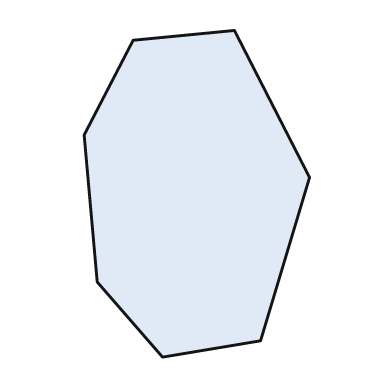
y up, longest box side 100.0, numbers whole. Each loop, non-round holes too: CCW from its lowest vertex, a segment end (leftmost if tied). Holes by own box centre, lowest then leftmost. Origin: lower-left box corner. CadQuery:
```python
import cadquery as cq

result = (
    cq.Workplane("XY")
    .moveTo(24.0, 0.0)
    .lineTo(54.0, 5.0)
    .lineTo(69.0, 55.0)
    .lineTo(46.0, 100.0)
    .lineTo(15.0, 97.0)
    .lineTo(0.0, 68.0)
    .lineTo(4.0, 23.0)
    .close()
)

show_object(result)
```